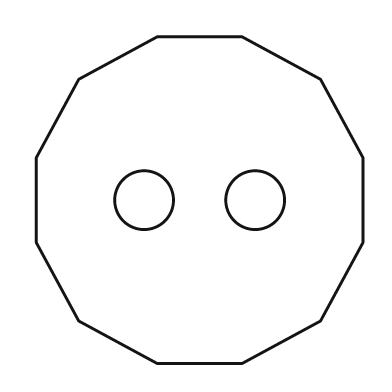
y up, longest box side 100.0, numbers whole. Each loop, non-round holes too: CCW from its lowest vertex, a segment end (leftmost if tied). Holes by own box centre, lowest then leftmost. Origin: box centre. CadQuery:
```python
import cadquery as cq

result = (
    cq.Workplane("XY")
    .moveTo(-13.0, -50.0)
    .lineTo(13.0, -50.0)
    .lineTo(37.0, -37.0)
    .lineTo(50.0, -13.0)
    .lineTo(50.0, 13.0)
    .lineTo(37.0, 37.0)
    .lineTo(13.0, 50.0)
    .lineTo(-13.0, 50.0)
    .lineTo(-37.0, 37.0)
    .lineTo(-50.0, 13.0)
    .lineTo(-50.0, -13.0)
    .lineTo(-37.0, -37.0)
    .close()
    .moveTo(-17.0, 0.0)
    .circle(9.0)
    .moveTo(17.0, 0.0)
    .circle(9.0)
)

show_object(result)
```